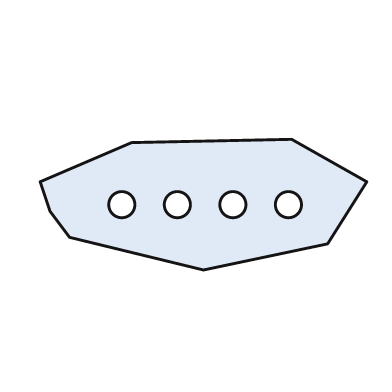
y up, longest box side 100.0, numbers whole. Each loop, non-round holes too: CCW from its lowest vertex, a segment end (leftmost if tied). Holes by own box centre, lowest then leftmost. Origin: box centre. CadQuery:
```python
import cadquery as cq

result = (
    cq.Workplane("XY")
    .moveTo(0.0, -20.0)
    .lineTo(38.0, -12.0)
    .lineTo(50.0, 7.0)
    .lineTo(27.0, 20.0)
    .lineTo(-22.0, 19.0)
    .lineTo(-50.0, 7.0)
    .lineTo(-47.0, -2.0)
    .lineTo(-41.0, -10.0)
    .close()
    .moveTo(-25.0, 0.0)
    .circle(4.0)
    .moveTo(-8.0, 0.0)
    .circle(4.0)
    .moveTo(9.0, 0.0)
    .circle(4.0)
    .moveTo(26.0, 0.0)
    .circle(4.0)
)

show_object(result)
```